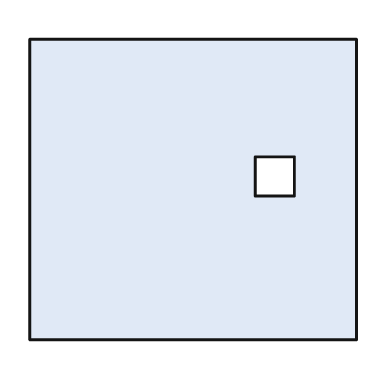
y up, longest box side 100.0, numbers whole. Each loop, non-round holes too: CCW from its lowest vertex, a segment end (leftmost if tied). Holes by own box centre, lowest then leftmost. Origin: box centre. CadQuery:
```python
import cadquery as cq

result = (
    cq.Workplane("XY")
    .moveTo(-50.0, -46.0)
    .lineTo(50.0, -46.0)
    .lineTo(50.0, 46.0)
    .lineTo(-50.0, 46.0)
    .close()
    .moveTo(19.0, -2.0)
    .lineTo(31.0, -2.0)
    .lineTo(31.0, 10.0)
    .lineTo(19.0, 10.0)
    .close()
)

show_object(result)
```